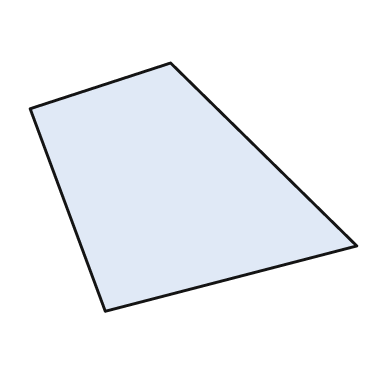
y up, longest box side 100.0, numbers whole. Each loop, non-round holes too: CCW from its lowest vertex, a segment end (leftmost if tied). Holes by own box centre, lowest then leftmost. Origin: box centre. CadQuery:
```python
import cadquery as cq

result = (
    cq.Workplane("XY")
    .moveTo(-27.0, -38.0)
    .lineTo(50.0, -18.0)
    .lineTo(-7.0, 38.0)
    .lineTo(-50.0, 24.0)
    .close()
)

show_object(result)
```